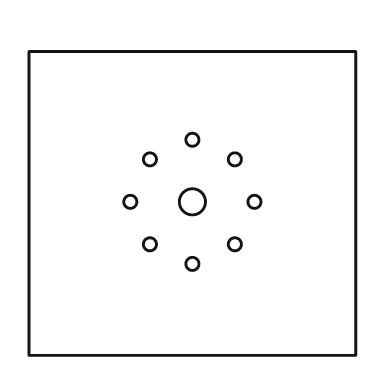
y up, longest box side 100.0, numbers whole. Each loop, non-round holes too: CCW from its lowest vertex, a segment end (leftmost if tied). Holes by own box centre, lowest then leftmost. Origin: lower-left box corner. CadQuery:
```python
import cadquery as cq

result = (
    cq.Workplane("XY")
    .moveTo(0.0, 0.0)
    .lineTo(100.0, 0.0)
    .lineTo(100.0, 93.0)
    .lineTo(0.0, 93.0)
    .close()
    .moveTo(50.0, 28.0)
    .circle(2.0)
    .moveTo(37.0, 34.0)
    .circle(2.0)
    .moveTo(63.0, 34.0)
    .circle(2.0)
    .moveTo(31.0, 47.0)
    .circle(2.0)
    .moveTo(50.0, 47.0)
    .circle(4.0)
    .moveTo(69.0, 47.0)
    .circle(2.0)
    .moveTo(37.0, 60.0)
    .circle(2.0)
    .moveTo(63.0, 60.0)
    .circle(2.0)
    .moveTo(50.0, 66.0)
    .circle(2.0)
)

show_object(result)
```